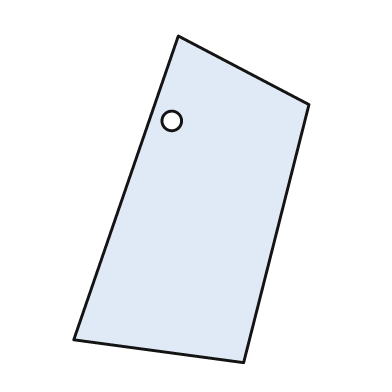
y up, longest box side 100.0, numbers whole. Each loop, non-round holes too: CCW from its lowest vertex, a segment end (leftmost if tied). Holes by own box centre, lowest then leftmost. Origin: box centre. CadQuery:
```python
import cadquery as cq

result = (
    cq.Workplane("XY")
    .moveTo(16.0, -50.0)
    .lineTo(36.0, 29.0)
    .lineTo(-4.0, 50.0)
    .lineTo(-36.0, -43.0)
    .close()
    .moveTo(-6.0, 24.0)
    .circle(3.0)
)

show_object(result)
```